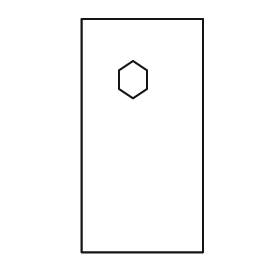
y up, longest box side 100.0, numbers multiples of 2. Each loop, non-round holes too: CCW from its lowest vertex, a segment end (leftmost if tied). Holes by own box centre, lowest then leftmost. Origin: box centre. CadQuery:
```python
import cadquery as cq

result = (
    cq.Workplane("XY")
    .moveTo(-26.0, -50.0)
    .lineTo(26.0, -50.0)
    .lineTo(26.0, 50.0)
    .lineTo(-26.0, 50.0)
    .close()
    .moveTo(-4.0, 16.0)
    .lineTo(2.0, 20.0)
    .lineTo(2.0, 28.0)
    .lineTo(-4.0, 32.0)
    .lineTo(-10.0, 28.0)
    .lineTo(-10.0, 20.0)
    .close()
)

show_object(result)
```